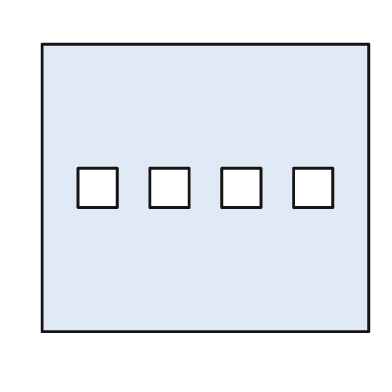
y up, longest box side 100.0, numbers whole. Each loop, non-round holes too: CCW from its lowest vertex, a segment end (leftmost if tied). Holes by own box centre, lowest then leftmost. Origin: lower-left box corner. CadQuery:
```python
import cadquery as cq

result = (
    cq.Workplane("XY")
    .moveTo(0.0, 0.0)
    .lineTo(100.0, 0.0)
    .lineTo(100.0, 88.0)
    .lineTo(0.0, 88.0)
    .close()
    .moveTo(11.0, 38.0)
    .lineTo(23.0, 38.0)
    .lineTo(23.0, 50.0)
    .lineTo(11.0, 50.0)
    .close()
    .moveTo(33.0, 38.0)
    .lineTo(45.0, 38.0)
    .lineTo(45.0, 50.0)
    .lineTo(33.0, 50.0)
    .close()
    .moveTo(55.0, 38.0)
    .lineTo(67.0, 38.0)
    .lineTo(67.0, 50.0)
    .lineTo(55.0, 50.0)
    .close()
    .moveTo(77.0, 38.0)
    .lineTo(89.0, 38.0)
    .lineTo(89.0, 50.0)
    .lineTo(77.0, 50.0)
    .close()
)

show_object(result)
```